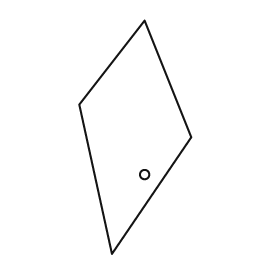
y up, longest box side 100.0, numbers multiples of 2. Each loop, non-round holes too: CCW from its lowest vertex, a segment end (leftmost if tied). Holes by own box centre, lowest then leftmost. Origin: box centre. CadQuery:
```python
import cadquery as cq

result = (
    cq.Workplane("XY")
    .moveTo(-10.0, -50.0)
    .lineTo(24.0, 0.0)
    .lineTo(4.0, 50.0)
    .lineTo(-24.0, 14.0)
    .close()
    .moveTo(4.0, -16.0)
    .circle(2.0)
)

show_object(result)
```